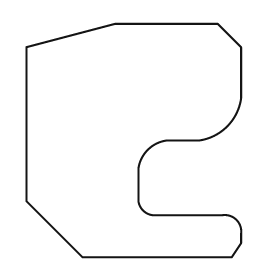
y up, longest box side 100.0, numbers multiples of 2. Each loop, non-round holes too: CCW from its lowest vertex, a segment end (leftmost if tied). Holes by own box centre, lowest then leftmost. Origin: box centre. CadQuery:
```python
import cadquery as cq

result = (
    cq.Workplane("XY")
    .moveTo(-22.0, -50.0)
    .lineTo(42.0, -50.0)
    .lineTo(46.0, -44.0)
    .lineTo(46.0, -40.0)
    .threePointArc((44.0, -34.0), (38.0, -32.0))
    .lineTo(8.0, -32.0)
    .threePointArc((4.0, -30.0), (2.0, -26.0))
    .lineTo(2.0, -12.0)
    .threePointArc((6.0, -4.0), (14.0, 0.0))
    .lineTo(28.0, 0.0)
    .threePointArc((40.0, 6.0), (46.0, 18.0))
    .lineTo(46.0, 40.0)
    .lineTo(36.0, 50.0)
    .lineTo(-8.0, 50.0)
    .lineTo(-46.0, 40.0)
    .lineTo(-46.0, -26.0)
    .close()
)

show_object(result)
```